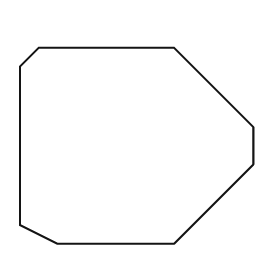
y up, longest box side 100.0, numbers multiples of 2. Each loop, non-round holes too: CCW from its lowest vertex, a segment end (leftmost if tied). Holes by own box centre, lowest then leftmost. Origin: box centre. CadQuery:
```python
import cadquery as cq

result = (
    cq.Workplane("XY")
    .moveTo(-34.0, -42.0)
    .lineTo(16.0, -42.0)
    .lineTo(50.0, -8.0)
    .lineTo(50.0, 8.0)
    .lineTo(16.0, 42.0)
    .lineTo(-42.0, 42.0)
    .lineTo(-50.0, 34.0)
    .lineTo(-50.0, -34.0)
    .close()
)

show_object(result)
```